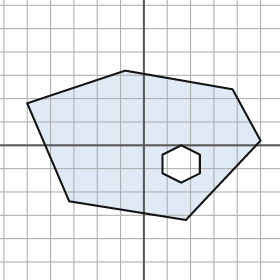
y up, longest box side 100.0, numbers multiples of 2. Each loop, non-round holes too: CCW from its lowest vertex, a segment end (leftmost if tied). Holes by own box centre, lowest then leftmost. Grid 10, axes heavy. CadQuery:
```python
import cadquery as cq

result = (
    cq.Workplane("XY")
    .moveTo(18.0, -32.0)
    .lineTo(50.0, 2.0)
    .lineTo(38.0, 24.0)
    .lineTo(-8.0, 32.0)
    .lineTo(-50.0, 18.0)
    .lineTo(-32.0, -24.0)
    .close()
    .moveTo(16.0, -16.0)
    .lineTo(24.0, -12.0)
    .lineTo(24.0, -4.0)
    .lineTo(16.0, 0.0)
    .lineTo(8.0, -4.0)
    .lineTo(8.0, -12.0)
    .close()
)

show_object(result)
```